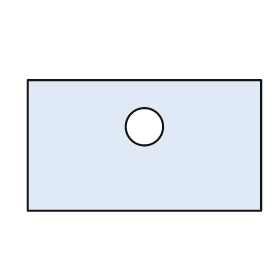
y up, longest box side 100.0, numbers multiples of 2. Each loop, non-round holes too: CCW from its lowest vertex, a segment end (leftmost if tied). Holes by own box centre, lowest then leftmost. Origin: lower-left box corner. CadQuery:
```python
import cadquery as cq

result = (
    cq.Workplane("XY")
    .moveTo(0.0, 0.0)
    .lineTo(100.0, 0.0)
    .lineTo(100.0, 56.0)
    .lineTo(0.0, 56.0)
    .close()
    .moveTo(50.0, 36.0)
    .circle(8.0)
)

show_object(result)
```